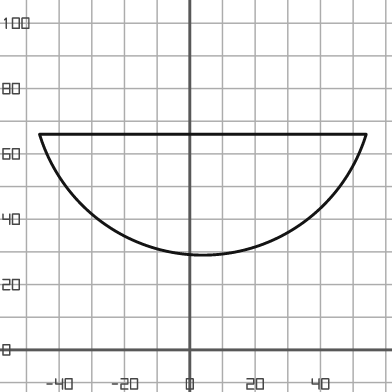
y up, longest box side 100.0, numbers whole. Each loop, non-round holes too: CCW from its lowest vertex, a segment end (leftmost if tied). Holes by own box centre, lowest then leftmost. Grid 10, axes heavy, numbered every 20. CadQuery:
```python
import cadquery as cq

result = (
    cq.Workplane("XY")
    .moveTo(-46.0, 66.0)
    .threePointArc((4.0, 29.0), (54.0, 66.0))
    .close()
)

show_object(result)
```